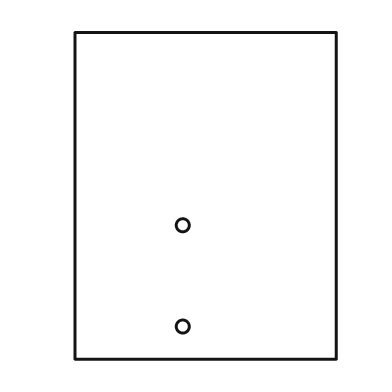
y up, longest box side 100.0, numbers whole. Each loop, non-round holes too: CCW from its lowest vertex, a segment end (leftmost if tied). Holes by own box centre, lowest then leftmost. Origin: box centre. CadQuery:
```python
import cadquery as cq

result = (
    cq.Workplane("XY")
    .moveTo(-40.0, -50.0)
    .lineTo(40.0, -50.0)
    .lineTo(40.0, 50.0)
    .lineTo(-40.0, 50.0)
    .close()
    .moveTo(-7.0, -40.0)
    .circle(2.0)
    .moveTo(-7.0, -9.0)
    .circle(2.0)
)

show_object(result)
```